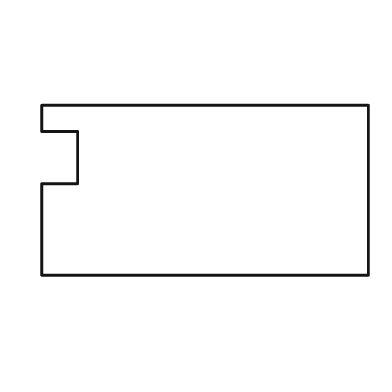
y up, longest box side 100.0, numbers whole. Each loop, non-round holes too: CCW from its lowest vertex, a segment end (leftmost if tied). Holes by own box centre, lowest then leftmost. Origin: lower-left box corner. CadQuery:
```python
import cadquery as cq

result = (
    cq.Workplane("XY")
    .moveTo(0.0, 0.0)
    .lineTo(100.0, 0.0)
    .lineTo(100.0, 52.0)
    .lineTo(0.0, 52.0)
    .lineTo(0.0, 44.0)
    .lineTo(11.0, 44.0)
    .lineTo(11.0, 28.0)
    .lineTo(0.0, 28.0)
    .close()
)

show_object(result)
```